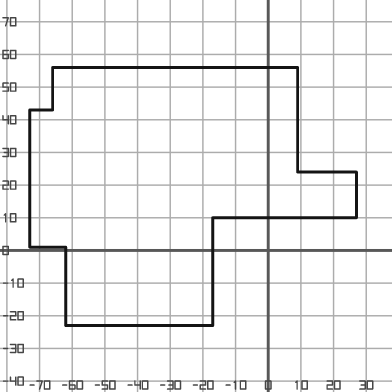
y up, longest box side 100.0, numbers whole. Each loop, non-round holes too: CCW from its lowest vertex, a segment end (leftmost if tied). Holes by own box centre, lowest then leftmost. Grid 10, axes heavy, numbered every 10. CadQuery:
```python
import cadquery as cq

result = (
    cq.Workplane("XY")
    .moveTo(-62.0, -23.0)
    .lineTo(-17.0, -23.0)
    .lineTo(-17.0, 10.0)
    .lineTo(27.0, 10.0)
    .lineTo(27.0, 24.0)
    .lineTo(9.0, 24.0)
    .lineTo(9.0, 56.0)
    .lineTo(-66.0, 56.0)
    .lineTo(-66.0, 43.0)
    .lineTo(-73.0, 43.0)
    .lineTo(-73.0, 1.0)
    .lineTo(-62.0, 1.0)
    .close()
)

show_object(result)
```